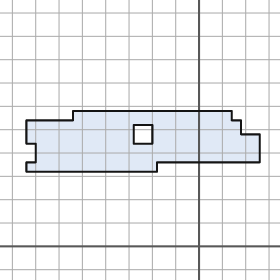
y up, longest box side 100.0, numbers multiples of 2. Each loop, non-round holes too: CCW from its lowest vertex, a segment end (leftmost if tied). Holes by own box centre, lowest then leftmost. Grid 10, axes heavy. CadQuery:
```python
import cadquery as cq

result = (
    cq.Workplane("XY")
    .moveTo(-74.0, 32.0)
    .lineTo(-18.0, 32.0)
    .lineTo(-18.0, 36.0)
    .lineTo(26.0, 36.0)
    .lineTo(26.0, 48.0)
    .lineTo(18.0, 48.0)
    .lineTo(18.0, 54.0)
    .lineTo(14.0, 54.0)
    .lineTo(14.0, 58.0)
    .lineTo(-54.0, 58.0)
    .lineTo(-54.0, 54.0)
    .lineTo(-74.0, 54.0)
    .lineTo(-74.0, 44.0)
    .lineTo(-70.0, 44.0)
    .lineTo(-70.0, 36.0)
    .lineTo(-74.0, 36.0)
    .close()
    .moveTo(-28.0, 44.0)
    .lineTo(-20.0, 44.0)
    .lineTo(-20.0, 52.0)
    .lineTo(-28.0, 52.0)
    .close()
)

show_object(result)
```